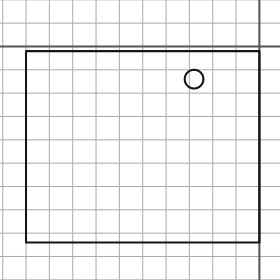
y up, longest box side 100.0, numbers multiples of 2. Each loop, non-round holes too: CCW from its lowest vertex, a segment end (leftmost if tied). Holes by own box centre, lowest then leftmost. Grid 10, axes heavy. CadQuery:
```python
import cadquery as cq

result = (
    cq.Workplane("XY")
    .moveTo(-100.0, -84.0)
    .lineTo(0.0, -84.0)
    .lineTo(0.0, -2.0)
    .lineTo(-100.0, -2.0)
    .close()
    .moveTo(-28.0, -14.0)
    .circle(4.0)
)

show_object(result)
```